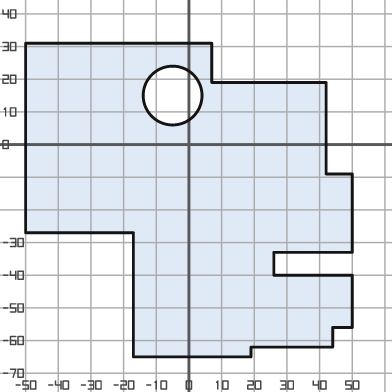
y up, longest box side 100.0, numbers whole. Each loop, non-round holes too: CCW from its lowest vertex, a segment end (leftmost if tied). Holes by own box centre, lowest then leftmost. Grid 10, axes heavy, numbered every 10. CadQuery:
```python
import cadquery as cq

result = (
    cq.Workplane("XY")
    .moveTo(-17.0, -65.0)
    .lineTo(19.0, -65.0)
    .lineTo(19.0, -62.0)
    .lineTo(44.0, -62.0)
    .lineTo(44.0, -56.0)
    .lineTo(50.0, -56.0)
    .lineTo(50.0, -40.0)
    .lineTo(26.0, -40.0)
    .lineTo(26.0, -33.0)
    .lineTo(50.0, -33.0)
    .lineTo(50.0, -9.0)
    .lineTo(42.0, -9.0)
    .lineTo(42.0, 19.0)
    .lineTo(7.0, 19.0)
    .lineTo(7.0, 31.0)
    .lineTo(-50.0, 31.0)
    .lineTo(-50.0, -27.0)
    .lineTo(-17.0, -27.0)
    .close()
    .moveTo(-5.0, 15.0)
    .circle(9.0)
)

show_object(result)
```